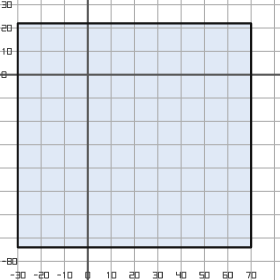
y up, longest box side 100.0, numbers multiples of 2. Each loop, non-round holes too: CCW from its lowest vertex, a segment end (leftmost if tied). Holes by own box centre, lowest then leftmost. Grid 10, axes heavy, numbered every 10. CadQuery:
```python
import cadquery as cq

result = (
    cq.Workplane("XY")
    .moveTo(-30.0, -74.0)
    .lineTo(70.0, -74.0)
    .lineTo(70.0, 22.0)
    .lineTo(-30.0, 22.0)
    .close()
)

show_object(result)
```